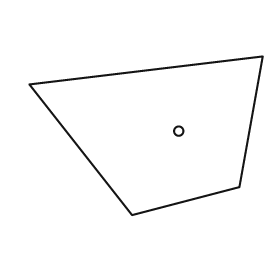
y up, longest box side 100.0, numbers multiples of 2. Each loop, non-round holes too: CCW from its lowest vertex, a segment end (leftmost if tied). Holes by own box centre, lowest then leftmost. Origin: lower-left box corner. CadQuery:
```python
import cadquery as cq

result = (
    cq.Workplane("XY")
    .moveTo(44.0, 0.0)
    .lineTo(90.0, 12.0)
    .lineTo(100.0, 68.0)
    .lineTo(0.0, 56.0)
    .close()
    .moveTo(64.0, 36.0)
    .circle(2.0)
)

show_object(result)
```